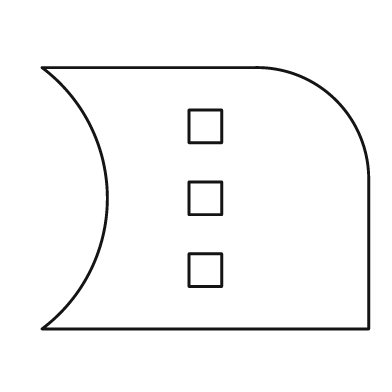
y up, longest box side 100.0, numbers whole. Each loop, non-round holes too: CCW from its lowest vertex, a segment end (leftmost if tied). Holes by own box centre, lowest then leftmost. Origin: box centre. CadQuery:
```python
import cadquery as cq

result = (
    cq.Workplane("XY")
    .moveTo(-50.0, -40.0)
    .lineTo(50.0, -40.0)
    .lineTo(50.0, 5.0)
    .threePointArc((40.0, 30.0), (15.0, 40.0))
    .lineTo(-50.0, 40.0)
    .threePointArc((-30.0, 0.0), (-50.0, -40.0))
    .close()
    .moveTo(-5.0, -27.0)
    .lineTo(5.0, -27.0)
    .lineTo(5.0, -17.0)
    .lineTo(-5.0, -17.0)
    .close()
    .moveTo(-5.0, -5.0)
    .lineTo(5.0, -5.0)
    .lineTo(5.0, 5.0)
    .lineTo(-5.0, 5.0)
    .close()
    .moveTo(-5.0, 17.0)
    .lineTo(5.0, 17.0)
    .lineTo(5.0, 27.0)
    .lineTo(-5.0, 27.0)
    .close()
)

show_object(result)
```